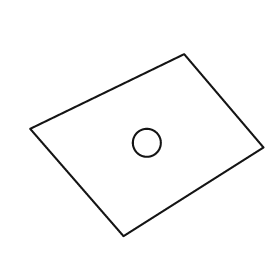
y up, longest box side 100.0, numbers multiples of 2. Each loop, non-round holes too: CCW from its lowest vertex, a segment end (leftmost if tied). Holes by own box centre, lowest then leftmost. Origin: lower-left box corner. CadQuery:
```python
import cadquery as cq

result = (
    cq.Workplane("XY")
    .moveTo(40.0, 0.0)
    .lineTo(100.0, 38.0)
    .lineTo(66.0, 78.0)
    .lineTo(0.0, 46.0)
    .close()
    .moveTo(50.0, 40.0)
    .circle(6.0)
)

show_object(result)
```